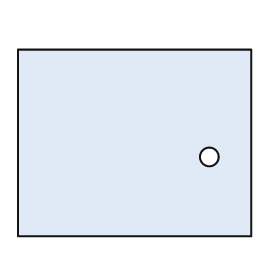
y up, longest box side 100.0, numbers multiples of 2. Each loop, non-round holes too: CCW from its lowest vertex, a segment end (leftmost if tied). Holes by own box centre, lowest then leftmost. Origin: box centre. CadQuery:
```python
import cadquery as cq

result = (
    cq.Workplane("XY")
    .moveTo(-50.0, -40.0)
    .lineTo(50.0, -40.0)
    .lineTo(50.0, 40.0)
    .lineTo(-50.0, 40.0)
    .close()
    .moveTo(32.0, -6.0)
    .circle(4.0)
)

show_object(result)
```